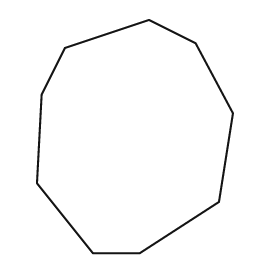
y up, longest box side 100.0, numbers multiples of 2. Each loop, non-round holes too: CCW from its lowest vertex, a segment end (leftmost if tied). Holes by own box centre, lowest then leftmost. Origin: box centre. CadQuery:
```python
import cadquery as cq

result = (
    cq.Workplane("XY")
    .moveTo(-18.0, -50.0)
    .lineTo(2.0, -50.0)
    .lineTo(36.0, -28.0)
    .lineTo(42.0, 10.0)
    .lineTo(26.0, 40.0)
    .lineTo(6.0, 50.0)
    .lineTo(-30.0, 38.0)
    .lineTo(-40.0, 18.0)
    .lineTo(-42.0, -20.0)
    .close()
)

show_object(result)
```